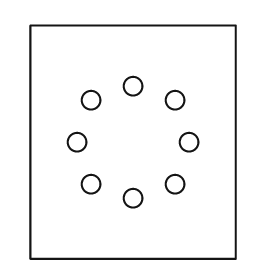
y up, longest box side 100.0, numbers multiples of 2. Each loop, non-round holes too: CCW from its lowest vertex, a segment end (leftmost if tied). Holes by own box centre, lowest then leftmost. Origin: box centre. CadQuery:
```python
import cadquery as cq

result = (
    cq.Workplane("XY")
    .moveTo(-44.0, -50.0)
    .lineTo(44.0, -50.0)
    .lineTo(44.0, 50.0)
    .lineTo(-44.0, 50.0)
    .close()
    .moveTo(0.0, -24.0)
    .circle(4.0)
    .moveTo(-18.0, -18.0)
    .circle(4.0)
    .moveTo(18.0, -18.0)
    .circle(4.0)
    .moveTo(-24.0, 0.0)
    .circle(4.0)
    .moveTo(24.0, 0.0)
    .circle(4.0)
    .moveTo(-18.0, 18.0)
    .circle(4.0)
    .moveTo(18.0, 18.0)
    .circle(4.0)
    .moveTo(0.0, 24.0)
    .circle(4.0)
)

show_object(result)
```